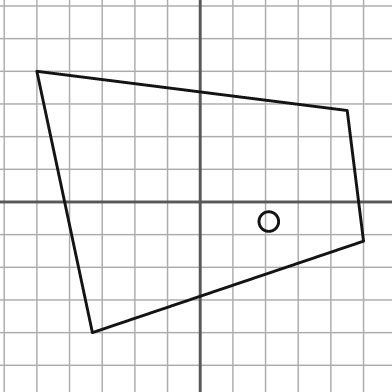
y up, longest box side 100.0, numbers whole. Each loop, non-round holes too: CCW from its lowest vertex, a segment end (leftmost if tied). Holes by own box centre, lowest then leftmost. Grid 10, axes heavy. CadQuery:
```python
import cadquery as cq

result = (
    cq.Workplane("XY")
    .moveTo(-33.0, -40.0)
    .lineTo(50.0, -12.0)
    .lineTo(45.0, 28.0)
    .lineTo(-50.0, 40.0)
    .close()
    .moveTo(21.0, -6.0)
    .circle(3.0)
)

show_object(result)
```